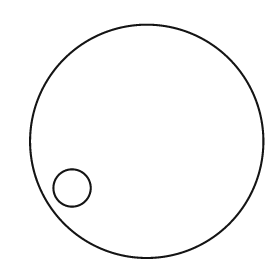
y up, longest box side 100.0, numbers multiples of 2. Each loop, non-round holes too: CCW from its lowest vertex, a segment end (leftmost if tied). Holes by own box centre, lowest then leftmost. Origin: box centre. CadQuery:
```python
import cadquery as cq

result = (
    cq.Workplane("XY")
    .moveTo(0.0, 0.0)
    .circle(50.0)
    .moveTo(-32.0, -20.0)
    .circle(8.0)
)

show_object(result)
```